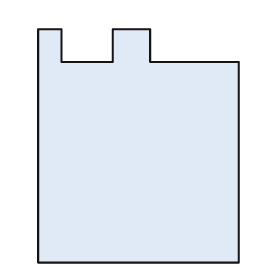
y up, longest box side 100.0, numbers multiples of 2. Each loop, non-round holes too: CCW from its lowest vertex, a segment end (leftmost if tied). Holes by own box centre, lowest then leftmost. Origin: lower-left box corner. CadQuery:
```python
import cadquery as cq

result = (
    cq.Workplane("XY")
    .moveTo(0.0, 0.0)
    .lineTo(86.0, 0.0)
    .lineTo(86.0, 86.0)
    .lineTo(48.0, 86.0)
    .lineTo(48.0, 100.0)
    .lineTo(32.0, 100.0)
    .lineTo(32.0, 86.0)
    .lineTo(10.0, 86.0)
    .lineTo(10.0, 100.0)
    .lineTo(0.0, 100.0)
    .close()
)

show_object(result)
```